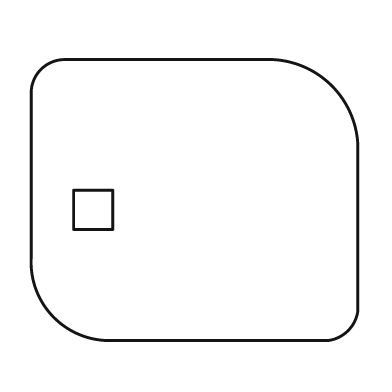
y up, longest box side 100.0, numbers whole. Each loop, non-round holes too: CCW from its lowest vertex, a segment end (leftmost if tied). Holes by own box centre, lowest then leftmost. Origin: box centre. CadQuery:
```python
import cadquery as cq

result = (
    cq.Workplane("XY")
    .moveTo(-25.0, -43.0)
    .lineTo(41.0, -43.0)
    .threePointArc((47.0, -40.0), (50.0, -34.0))
    .lineTo(50.0, 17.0)
    .threePointArc((42.0, 35.0), (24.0, 43.0))
    .lineTo(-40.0, 43.0)
    .threePointArc((-47.0, 40.0), (-50.0, 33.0))
    .lineTo(-50.0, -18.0)
    .threePointArc((-43.0, -36.0), (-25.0, -43.0))
    .close()
    .moveTo(-37.0, -9.0)
    .lineTo(-25.0, -9.0)
    .lineTo(-25.0, 3.0)
    .lineTo(-37.0, 3.0)
    .close()
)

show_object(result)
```